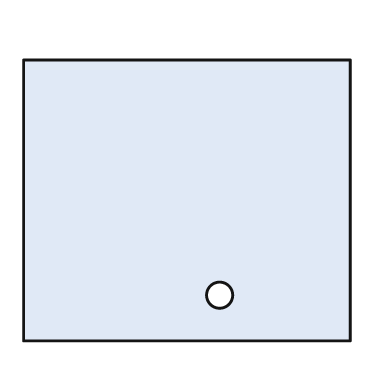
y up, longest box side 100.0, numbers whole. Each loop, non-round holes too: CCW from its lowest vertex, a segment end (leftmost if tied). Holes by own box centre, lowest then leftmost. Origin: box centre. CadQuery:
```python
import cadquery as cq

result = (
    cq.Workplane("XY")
    .moveTo(-50.0, -43.0)
    .lineTo(50.0, -43.0)
    .lineTo(50.0, 43.0)
    .lineTo(-50.0, 43.0)
    .close()
    .moveTo(10.0, -29.0)
    .circle(4.0)
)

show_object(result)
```